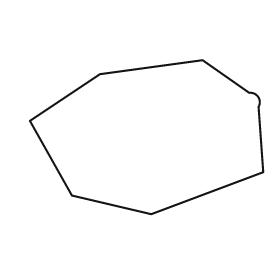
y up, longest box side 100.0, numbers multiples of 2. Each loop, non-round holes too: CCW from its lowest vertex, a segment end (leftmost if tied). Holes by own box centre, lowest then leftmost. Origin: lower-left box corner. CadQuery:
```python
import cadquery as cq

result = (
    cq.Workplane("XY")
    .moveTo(52.0, 0.0)
    .lineTo(100.0, 18.0)
    .lineTo(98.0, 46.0)
    .threePointArc((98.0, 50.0), (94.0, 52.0))
    .lineTo(74.0, 66.0)
    .lineTo(30.0, 60.0)
    .lineTo(0.0, 40.0)
    .lineTo(18.0, 8.0)
    .close()
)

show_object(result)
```